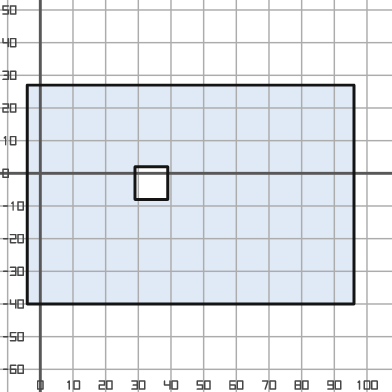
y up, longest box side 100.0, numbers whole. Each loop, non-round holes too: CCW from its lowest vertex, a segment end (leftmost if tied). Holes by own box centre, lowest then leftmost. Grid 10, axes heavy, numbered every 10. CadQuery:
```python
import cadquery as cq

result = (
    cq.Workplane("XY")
    .moveTo(-4.0, -40.0)
    .lineTo(96.0, -40.0)
    .lineTo(96.0, 27.0)
    .lineTo(-4.0, 27.0)
    .close()
    .moveTo(29.0, -8.0)
    .lineTo(39.0, -8.0)
    .lineTo(39.0, 2.0)
    .lineTo(29.0, 2.0)
    .close()
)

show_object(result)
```